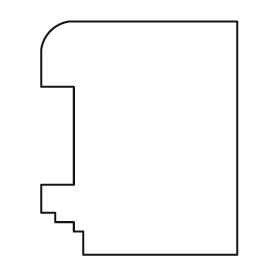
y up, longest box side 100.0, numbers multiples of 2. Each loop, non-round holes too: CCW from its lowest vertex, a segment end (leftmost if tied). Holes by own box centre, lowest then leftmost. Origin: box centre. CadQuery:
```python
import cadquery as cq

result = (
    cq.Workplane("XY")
    .moveTo(-24.0, -50.0)
    .lineTo(42.0, -50.0)
    .lineTo(42.0, 50.0)
    .lineTo(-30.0, 50.0)
    .threePointArc((-38.0, 46.0), (-42.0, 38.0))
    .lineTo(-42.0, 22.0)
    .lineTo(-28.0, 22.0)
    .lineTo(-28.0, -20.0)
    .lineTo(-42.0, -20.0)
    .lineTo(-42.0, -32.0)
    .lineTo(-36.0, -32.0)
    .lineTo(-36.0, -36.0)
    .lineTo(-28.0, -36.0)
    .lineTo(-28.0, -40.0)
    .lineTo(-24.0, -40.0)
    .close()
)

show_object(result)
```